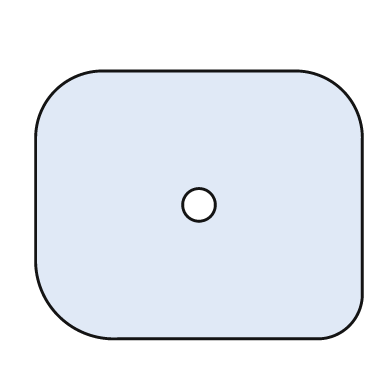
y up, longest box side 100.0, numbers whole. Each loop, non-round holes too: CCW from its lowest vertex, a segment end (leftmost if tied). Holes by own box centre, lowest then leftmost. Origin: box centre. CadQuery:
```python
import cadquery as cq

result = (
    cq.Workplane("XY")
    .moveTo(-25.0, -41.0)
    .lineTo(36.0, -41.0)
    .threePointArc((46.0, -37.0), (50.0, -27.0))
    .lineTo(50.0, 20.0)
    .threePointArc((44.0, 35.0), (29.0, 41.0))
    .lineTo(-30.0, 41.0)
    .threePointArc((-44.0, 35.0), (-50.0, 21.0))
    .lineTo(-50.0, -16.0)
    .threePointArc((-43.0, -34.0), (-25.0, -41.0))
    .close()
    .moveTo(0.0, 0.0)
    .circle(5.0)
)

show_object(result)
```